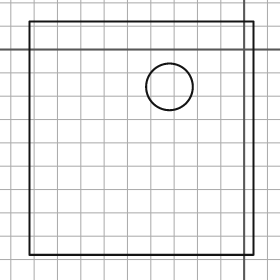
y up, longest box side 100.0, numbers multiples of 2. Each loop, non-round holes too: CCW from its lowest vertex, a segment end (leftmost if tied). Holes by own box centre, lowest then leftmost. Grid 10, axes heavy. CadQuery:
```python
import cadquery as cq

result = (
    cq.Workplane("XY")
    .moveTo(-92.0, -88.0)
    .lineTo(4.0, -88.0)
    .lineTo(4.0, 12.0)
    .lineTo(-92.0, 12.0)
    .close()
    .moveTo(-32.0, -16.0)
    .circle(10.0)
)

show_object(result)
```